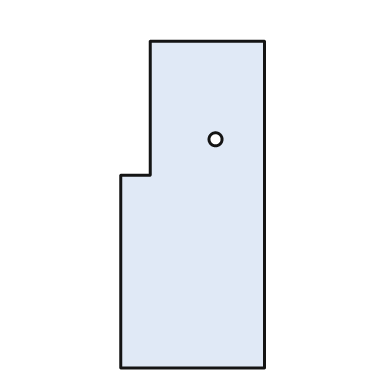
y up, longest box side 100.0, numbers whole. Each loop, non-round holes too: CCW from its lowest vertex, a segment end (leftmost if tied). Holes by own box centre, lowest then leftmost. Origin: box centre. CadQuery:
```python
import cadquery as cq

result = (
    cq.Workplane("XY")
    .moveTo(-22.0, -50.0)
    .lineTo(22.0, -50.0)
    .lineTo(22.0, 50.0)
    .lineTo(-13.0, 50.0)
    .lineTo(-13.0, 9.0)
    .lineTo(-22.0, 9.0)
    .close()
    .moveTo(7.0, 20.0)
    .circle(2.0)
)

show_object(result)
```